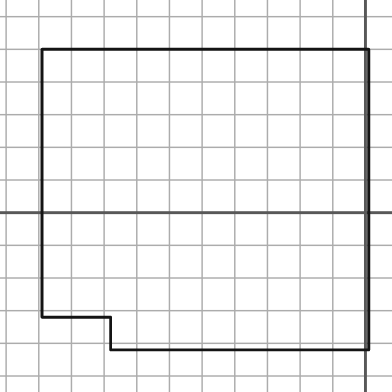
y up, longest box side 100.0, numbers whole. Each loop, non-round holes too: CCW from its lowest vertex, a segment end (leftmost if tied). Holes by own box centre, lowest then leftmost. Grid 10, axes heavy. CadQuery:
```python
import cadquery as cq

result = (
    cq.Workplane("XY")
    .moveTo(-78.0, -42.0)
    .lineTo(1.0, -42.0)
    .lineTo(1.0, 50.0)
    .lineTo(-99.0, 50.0)
    .lineTo(-99.0, -32.0)
    .lineTo(-78.0, -32.0)
    .close()
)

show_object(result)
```